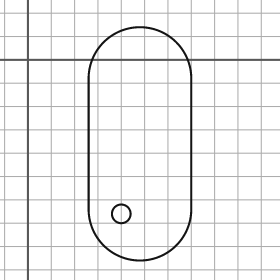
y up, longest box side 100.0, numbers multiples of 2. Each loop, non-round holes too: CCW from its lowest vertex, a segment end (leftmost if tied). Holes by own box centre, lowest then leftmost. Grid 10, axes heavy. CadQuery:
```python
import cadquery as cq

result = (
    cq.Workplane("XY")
    .moveTo(26.0, -64.0)
    .threePointArc((48.0, -86.0), (70.0, -64.0))
    .lineTo(70.0, -8.0)
    .threePointArc((48.0, 14.0), (26.0, -8.0))
    .close()
    .moveTo(40.0, -66.0)
    .circle(4.0)
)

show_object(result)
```